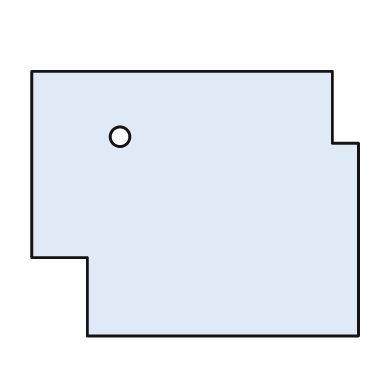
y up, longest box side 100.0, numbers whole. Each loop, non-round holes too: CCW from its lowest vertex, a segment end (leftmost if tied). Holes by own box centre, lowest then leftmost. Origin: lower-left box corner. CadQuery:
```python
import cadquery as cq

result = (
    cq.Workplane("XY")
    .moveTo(17.0, 0.0)
    .lineTo(100.0, 0.0)
    .lineTo(100.0, 59.0)
    .lineTo(92.0, 59.0)
    .lineTo(92.0, 81.0)
    .lineTo(0.0, 81.0)
    .lineTo(0.0, 24.0)
    .lineTo(17.0, 24.0)
    .close()
    .moveTo(27.0, 61.0)
    .circle(3.0)
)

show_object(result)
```